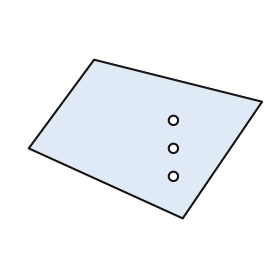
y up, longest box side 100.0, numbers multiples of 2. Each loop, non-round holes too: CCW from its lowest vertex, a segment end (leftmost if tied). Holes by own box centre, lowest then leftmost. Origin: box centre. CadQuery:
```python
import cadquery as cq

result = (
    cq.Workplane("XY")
    .moveTo(16.0, -34.0)
    .lineTo(50.0, 16.0)
    .lineTo(-22.0, 34.0)
    .lineTo(-50.0, -4.0)
    .close()
    .moveTo(12.0, -16.0)
    .circle(2.0)
    .moveTo(12.0, -4.0)
    .circle(2.0)
    .moveTo(12.0, 8.0)
    .circle(2.0)
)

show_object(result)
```